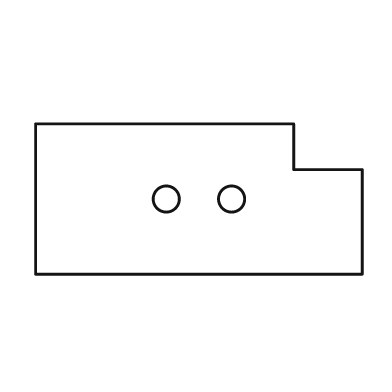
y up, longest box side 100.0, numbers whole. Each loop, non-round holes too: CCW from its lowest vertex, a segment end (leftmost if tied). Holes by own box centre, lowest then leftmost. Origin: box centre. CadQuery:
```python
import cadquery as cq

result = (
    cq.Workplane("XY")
    .moveTo(-50.0, -23.0)
    .lineTo(50.0, -23.0)
    .lineTo(50.0, 9.0)
    .lineTo(29.0, 9.0)
    .lineTo(29.0, 23.0)
    .lineTo(-50.0, 23.0)
    .close()
    .moveTo(-10.0, 0.0)
    .circle(4.0)
    .moveTo(10.0, 0.0)
    .circle(4.0)
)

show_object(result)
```